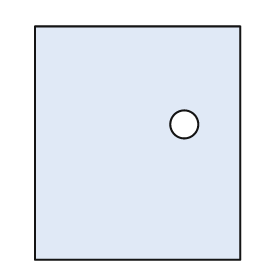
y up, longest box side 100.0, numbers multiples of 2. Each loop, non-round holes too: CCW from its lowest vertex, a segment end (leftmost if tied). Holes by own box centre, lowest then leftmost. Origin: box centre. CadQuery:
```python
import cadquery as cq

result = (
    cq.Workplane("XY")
    .moveTo(-44.0, -50.0)
    .lineTo(44.0, -50.0)
    .lineTo(44.0, 50.0)
    .lineTo(-44.0, 50.0)
    .close()
    .moveTo(20.0, 8.0)
    .circle(6.0)
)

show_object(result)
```